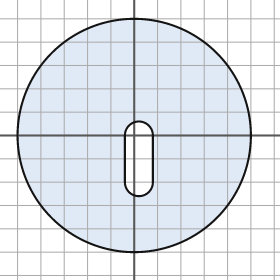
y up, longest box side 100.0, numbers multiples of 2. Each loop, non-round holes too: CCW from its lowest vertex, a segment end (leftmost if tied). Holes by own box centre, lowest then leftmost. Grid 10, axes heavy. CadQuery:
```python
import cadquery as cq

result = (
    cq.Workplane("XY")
    .moveTo(0.0, 0.0)
    .circle(50.0)
    .moveTo(-4.0, -20.0)
    .threePointArc((2.0, -26.0), (8.0, -20.0))
    .lineTo(8.0, 0.0)
    .threePointArc((2.0, 6.0), (-4.0, 0.0))
    .close()
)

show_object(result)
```